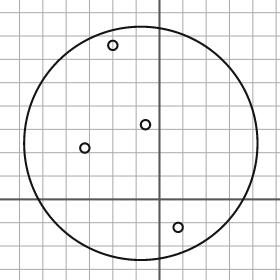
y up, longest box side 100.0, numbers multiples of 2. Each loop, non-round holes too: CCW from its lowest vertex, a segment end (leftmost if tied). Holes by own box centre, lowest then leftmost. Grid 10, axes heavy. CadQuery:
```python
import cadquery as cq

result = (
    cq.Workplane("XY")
    .moveTo(-8.0, 24.0)
    .circle(50.0)
    .moveTo(8.0, -12.0)
    .circle(2.0)
    .moveTo(-32.0, 22.0)
    .circle(2.0)
    .moveTo(-6.0, 32.0)
    .circle(2.0)
    .moveTo(-20.0, 66.0)
    .circle(2.0)
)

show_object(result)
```